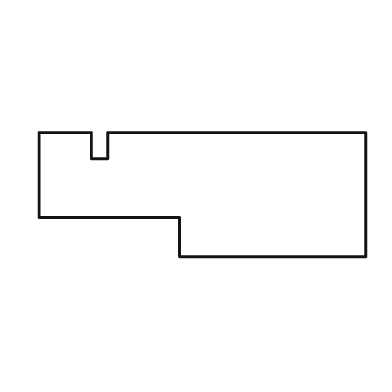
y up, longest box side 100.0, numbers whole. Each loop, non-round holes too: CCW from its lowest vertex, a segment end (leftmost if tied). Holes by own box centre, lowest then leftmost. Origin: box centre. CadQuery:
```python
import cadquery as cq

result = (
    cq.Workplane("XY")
    .moveTo(-7.0, -19.0)
    .lineTo(50.0, -19.0)
    .lineTo(50.0, 19.0)
    .lineTo(-29.0, 19.0)
    .lineTo(-29.0, 11.0)
    .lineTo(-34.0, 11.0)
    .lineTo(-34.0, 19.0)
    .lineTo(-50.0, 19.0)
    .lineTo(-50.0, -7.0)
    .lineTo(-7.0, -7.0)
    .close()
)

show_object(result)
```